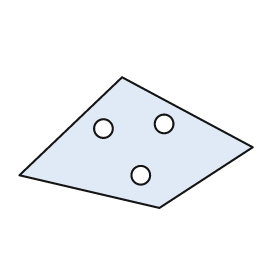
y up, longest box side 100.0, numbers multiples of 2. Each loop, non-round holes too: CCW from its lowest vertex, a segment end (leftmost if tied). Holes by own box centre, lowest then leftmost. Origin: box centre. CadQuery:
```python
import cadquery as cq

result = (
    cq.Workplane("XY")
    .moveTo(10.0, -28.0)
    .lineTo(50.0, -2.0)
    .lineTo(-6.0, 28.0)
    .lineTo(-50.0, -14.0)
    .close()
    .moveTo(2.0, -14.0)
    .circle(4.0)
    .moveTo(-14.0, 6.0)
    .circle(4.0)
    .moveTo(12.0, 8.0)
    .circle(4.0)
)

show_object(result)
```